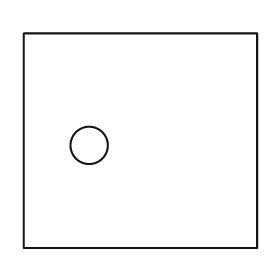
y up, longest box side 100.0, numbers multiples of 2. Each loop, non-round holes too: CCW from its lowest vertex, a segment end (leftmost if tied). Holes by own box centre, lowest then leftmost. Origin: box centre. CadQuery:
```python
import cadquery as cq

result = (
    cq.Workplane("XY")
    .moveTo(-50.0, -46.0)
    .lineTo(50.0, -46.0)
    .lineTo(50.0, 46.0)
    .lineTo(-50.0, 46.0)
    .close()
    .moveTo(-22.0, -2.0)
    .circle(8.0)
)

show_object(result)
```